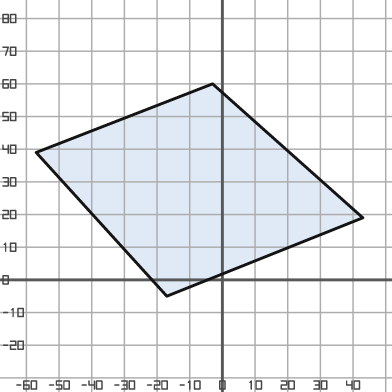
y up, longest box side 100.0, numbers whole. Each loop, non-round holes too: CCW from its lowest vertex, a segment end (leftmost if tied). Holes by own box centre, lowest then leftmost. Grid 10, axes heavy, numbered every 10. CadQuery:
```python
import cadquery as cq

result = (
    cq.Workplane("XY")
    .moveTo(-17.0, -5.0)
    .lineTo(43.0, 19.0)
    .lineTo(-3.0, 60.0)
    .lineTo(-57.0, 39.0)
    .close()
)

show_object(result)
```